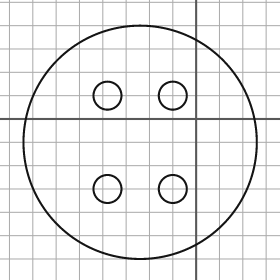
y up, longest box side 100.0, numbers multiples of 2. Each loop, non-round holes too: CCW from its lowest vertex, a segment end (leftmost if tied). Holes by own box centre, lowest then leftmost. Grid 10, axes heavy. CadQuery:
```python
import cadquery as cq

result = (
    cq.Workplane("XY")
    .moveTo(-24.0, -10.0)
    .circle(50.0)
    .moveTo(-38.0, -30.0)
    .circle(6.0)
    .moveTo(-10.0, -30.0)
    .circle(6.0)
    .moveTo(-38.0, 10.0)
    .circle(6.0)
    .moveTo(-10.0, 10.0)
    .circle(6.0)
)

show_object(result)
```